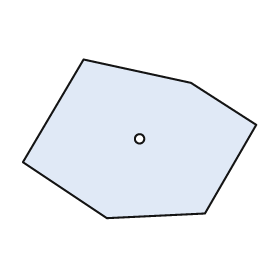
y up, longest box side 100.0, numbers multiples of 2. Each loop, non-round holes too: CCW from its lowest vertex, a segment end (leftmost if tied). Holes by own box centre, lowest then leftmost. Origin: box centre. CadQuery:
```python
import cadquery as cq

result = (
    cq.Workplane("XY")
    .moveTo(-14.0, -34.0)
    .lineTo(28.0, -32.0)
    .lineTo(50.0, 6.0)
    .lineTo(22.0, 24.0)
    .lineTo(-24.0, 34.0)
    .lineTo(-50.0, -10.0)
    .close()
    .moveTo(0.0, 0.0)
    .circle(2.0)
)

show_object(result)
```